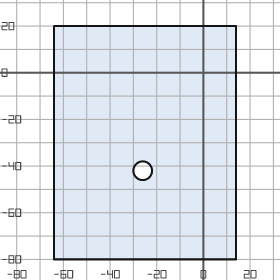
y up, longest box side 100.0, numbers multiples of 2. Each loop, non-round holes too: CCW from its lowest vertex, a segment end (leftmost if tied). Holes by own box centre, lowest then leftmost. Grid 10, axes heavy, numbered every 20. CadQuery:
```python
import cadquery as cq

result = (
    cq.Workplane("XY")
    .moveTo(-64.0, -80.0)
    .lineTo(14.0, -80.0)
    .lineTo(14.0, 20.0)
    .lineTo(-64.0, 20.0)
    .close()
    .moveTo(-26.0, -42.0)
    .circle(4.0)
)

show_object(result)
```